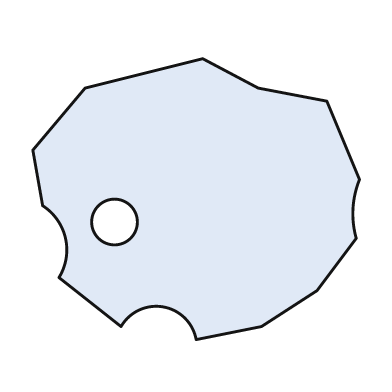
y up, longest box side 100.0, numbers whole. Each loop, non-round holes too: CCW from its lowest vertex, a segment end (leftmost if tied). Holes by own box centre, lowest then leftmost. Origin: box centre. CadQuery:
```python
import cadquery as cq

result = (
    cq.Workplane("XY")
    .moveTo(0.0, -43.0)
    .lineTo(20.0, -39.0)
    .lineTo(37.0, -28.0)
    .lineTo(49.0, -12.0)
    .threePointArc((48.0, -3.0), (50.0, 6.0))
    .lineTo(40.0, 30.0)
    .lineTo(19.0, 34.0)
    .lineTo(2.0, 43.0)
    .lineTo(-34.0, 34.0)
    .lineTo(-50.0, 15.0)
    .lineTo(-47.0, -2.0)
    .threePointArc((-40.0, -12.0), (-42.0, -24.0))
    .lineTo(-23.0, -39.0)
    .threePointArc((-10.0, -33.0), (0.0, -43.0))
    .close()
    .moveTo(-25.0, -7.0)
    .circle(7.0)
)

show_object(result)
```